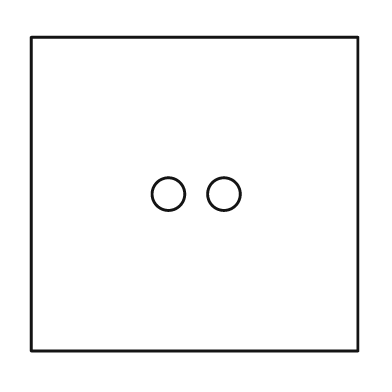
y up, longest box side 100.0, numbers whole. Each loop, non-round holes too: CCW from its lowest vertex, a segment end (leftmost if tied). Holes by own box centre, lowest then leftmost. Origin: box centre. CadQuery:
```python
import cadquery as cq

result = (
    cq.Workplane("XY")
    .moveTo(-50.0, -48.0)
    .lineTo(50.0, -48.0)
    .lineTo(50.0, 48.0)
    .lineTo(-50.0, 48.0)
    .close()
    .moveTo(-8.0, 0.0)
    .circle(5.0)
    .moveTo(9.0, 0.0)
    .circle(5.0)
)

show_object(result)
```